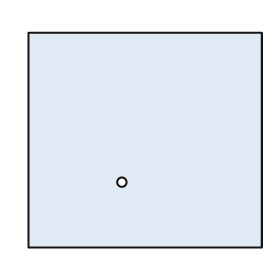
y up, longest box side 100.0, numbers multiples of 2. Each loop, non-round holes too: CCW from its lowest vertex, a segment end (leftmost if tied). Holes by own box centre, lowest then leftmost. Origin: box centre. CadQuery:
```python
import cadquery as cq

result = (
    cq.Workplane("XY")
    .moveTo(-50.0, -46.0)
    .lineTo(50.0, -46.0)
    .lineTo(50.0, 46.0)
    .lineTo(-50.0, 46.0)
    .close()
    .moveTo(-10.0, -18.0)
    .circle(2.0)
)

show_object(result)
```